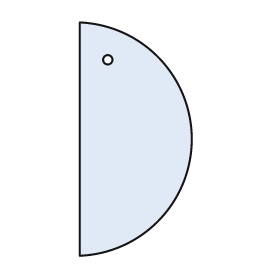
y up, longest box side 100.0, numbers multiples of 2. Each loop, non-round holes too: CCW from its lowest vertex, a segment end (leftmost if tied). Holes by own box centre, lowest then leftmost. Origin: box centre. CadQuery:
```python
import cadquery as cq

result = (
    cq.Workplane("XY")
    .moveTo(-24.0, -50.0)
    .threePointArc((24.0, 0.0), (-24.0, 50.0))
    .close()
    .moveTo(-12.0, 34.0)
    .circle(2.0)
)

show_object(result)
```